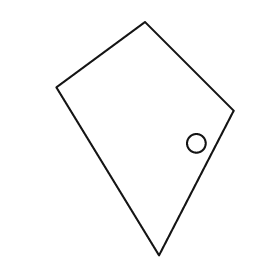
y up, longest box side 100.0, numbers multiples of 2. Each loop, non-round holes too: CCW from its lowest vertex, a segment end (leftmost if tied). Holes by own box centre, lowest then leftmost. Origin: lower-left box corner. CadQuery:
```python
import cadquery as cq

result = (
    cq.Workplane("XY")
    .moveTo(44.0, 0.0)
    .lineTo(76.0, 62.0)
    .lineTo(38.0, 100.0)
    .lineTo(0.0, 72.0)
    .close()
    .moveTo(60.0, 48.0)
    .circle(4.0)
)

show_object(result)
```